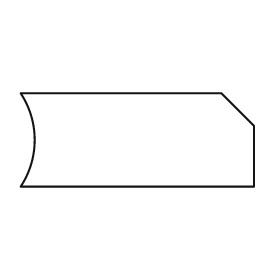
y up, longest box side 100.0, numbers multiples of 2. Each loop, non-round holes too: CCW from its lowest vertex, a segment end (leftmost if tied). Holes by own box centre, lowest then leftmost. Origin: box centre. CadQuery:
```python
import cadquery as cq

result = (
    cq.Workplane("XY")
    .moveTo(-50.0, -20.0)
    .lineTo(50.0, -20.0)
    .lineTo(50.0, 6.0)
    .lineTo(36.0, 20.0)
    .lineTo(-50.0, 20.0)
    .threePointArc((-44.0, 0.0), (-50.0, -20.0))
    .close()
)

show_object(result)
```